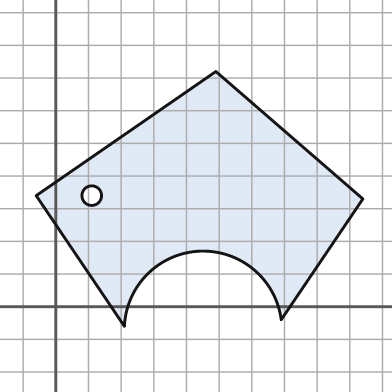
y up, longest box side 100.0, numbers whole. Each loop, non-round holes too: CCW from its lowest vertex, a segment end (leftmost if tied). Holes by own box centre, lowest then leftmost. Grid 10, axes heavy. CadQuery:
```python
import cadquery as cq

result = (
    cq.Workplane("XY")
    .moveTo(21.0, -6.0)
    .threePointArc((44.0, 17.0), (69.0, -4.0))
    .lineTo(94.0, 33.0)
    .lineTo(49.0, 72.0)
    .lineTo(-6.0, 34.0)
    .close()
    .moveTo(11.0, 34.0)
    .circle(3.0)
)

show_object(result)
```